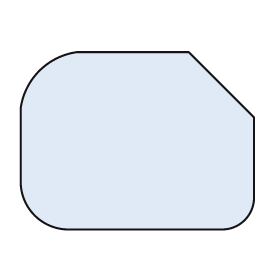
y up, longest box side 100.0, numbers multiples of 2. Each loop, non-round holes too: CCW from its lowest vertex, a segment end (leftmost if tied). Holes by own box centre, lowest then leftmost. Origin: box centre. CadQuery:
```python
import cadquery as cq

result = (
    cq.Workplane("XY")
    .moveTo(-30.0, -38.0)
    .lineTo(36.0, -38.0)
    .threePointArc((46.0, -34.0), (50.0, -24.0))
    .lineTo(50.0, 10.0)
    .lineTo(22.0, 38.0)
    .lineTo(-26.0, 38.0)
    .threePointArc((-42.0, 30.0), (-50.0, 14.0))
    .lineTo(-50.0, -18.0)
    .threePointArc((-44.0, -32.0), (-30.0, -38.0))
    .close()
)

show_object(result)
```